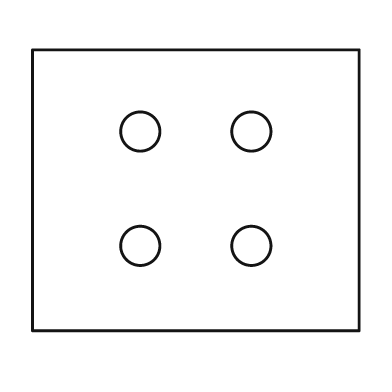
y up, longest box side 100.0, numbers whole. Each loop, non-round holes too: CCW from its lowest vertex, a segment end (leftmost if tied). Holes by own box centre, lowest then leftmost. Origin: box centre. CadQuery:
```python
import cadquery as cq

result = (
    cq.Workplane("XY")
    .moveTo(-50.0, -43.0)
    .lineTo(50.0, -43.0)
    .lineTo(50.0, 43.0)
    .lineTo(-50.0, 43.0)
    .close()
    .moveTo(-17.0, -17.0)
    .circle(6.0)
    .moveTo(17.0, -17.0)
    .circle(6.0)
    .moveTo(-17.0, 18.0)
    .circle(6.0)
    .moveTo(17.0, 18.0)
    .circle(6.0)
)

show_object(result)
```